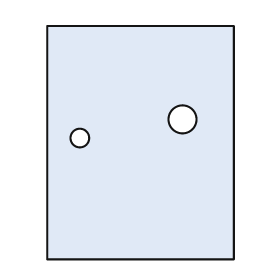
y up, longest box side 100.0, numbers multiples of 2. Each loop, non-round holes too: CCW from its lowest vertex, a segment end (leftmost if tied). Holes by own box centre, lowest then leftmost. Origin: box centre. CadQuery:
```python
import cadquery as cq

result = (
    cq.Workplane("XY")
    .moveTo(-40.0, -50.0)
    .lineTo(40.0, -50.0)
    .lineTo(40.0, 50.0)
    .lineTo(-40.0, 50.0)
    .close()
    .moveTo(-26.0, 2.0)
    .circle(4.0)
    .moveTo(18.0, 10.0)
    .circle(6.0)
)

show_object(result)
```